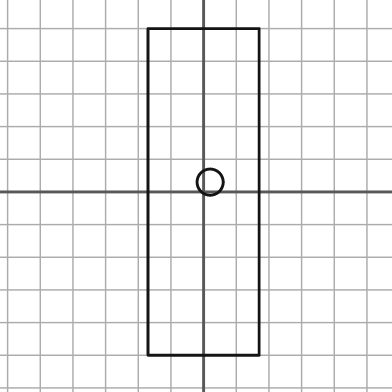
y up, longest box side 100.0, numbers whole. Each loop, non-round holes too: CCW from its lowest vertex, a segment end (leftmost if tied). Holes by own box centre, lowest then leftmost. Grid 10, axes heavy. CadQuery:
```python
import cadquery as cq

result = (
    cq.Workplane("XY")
    .moveTo(-17.0, -50.0)
    .lineTo(17.0, -50.0)
    .lineTo(17.0, 50.0)
    .lineTo(-17.0, 50.0)
    .close()
    .moveTo(2.0, 3.0)
    .circle(4.0)
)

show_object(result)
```